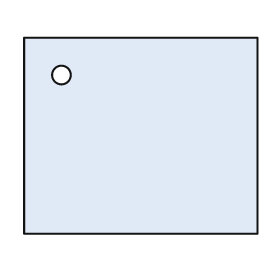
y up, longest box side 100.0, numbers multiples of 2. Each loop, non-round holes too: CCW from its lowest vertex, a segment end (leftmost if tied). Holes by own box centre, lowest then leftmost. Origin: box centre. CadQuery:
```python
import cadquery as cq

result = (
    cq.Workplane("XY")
    .moveTo(-50.0, -42.0)
    .lineTo(50.0, -42.0)
    .lineTo(50.0, 42.0)
    .lineTo(-50.0, 42.0)
    .close()
    .moveTo(-34.0, 26.0)
    .circle(4.0)
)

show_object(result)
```